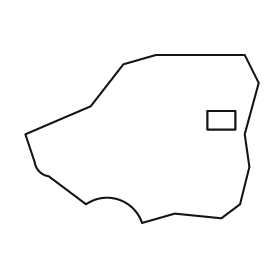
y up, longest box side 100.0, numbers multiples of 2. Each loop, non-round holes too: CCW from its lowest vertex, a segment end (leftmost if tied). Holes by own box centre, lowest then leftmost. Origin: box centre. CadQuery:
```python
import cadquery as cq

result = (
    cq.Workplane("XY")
    .moveTo(0.0, -36.0)
    .lineTo(14.0, -32.0)
    .lineTo(34.0, -34.0)
    .lineTo(42.0, -28.0)
    .lineTo(46.0, -12.0)
    .lineTo(44.0, 2.0)
    .lineTo(50.0, 24.0)
    .lineTo(44.0, 36.0)
    .lineTo(6.0, 36.0)
    .lineTo(-8.0, 32.0)
    .lineTo(-22.0, 14.0)
    .lineTo(-50.0, 2.0)
    .lineTo(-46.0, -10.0)
    .threePointArc((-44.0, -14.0), (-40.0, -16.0))
    .lineTo(-24.0, -28.0)
    .threePointArc((-10.0, -26.0), (0.0, -36.0))
    .close()
    .moveTo(28.0, 4.0)
    .lineTo(40.0, 4.0)
    .lineTo(40.0, 12.0)
    .lineTo(28.0, 12.0)
    .close()
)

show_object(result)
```